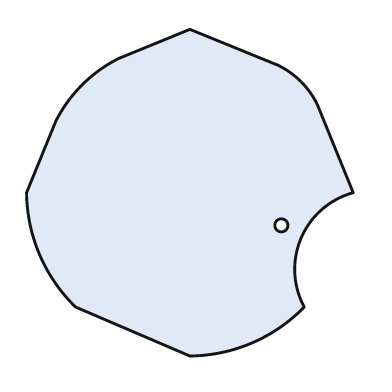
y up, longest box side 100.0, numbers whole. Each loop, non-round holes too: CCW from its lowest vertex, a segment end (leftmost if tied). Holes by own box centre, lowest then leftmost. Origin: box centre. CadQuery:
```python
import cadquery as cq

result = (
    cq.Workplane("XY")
    .moveTo(0.0, -50.0)
    .threePointArc((19.0, -46.0), (35.0, -35.0))
    .threePointArc((34.0, -14.0), (50.0, 0.0))
    .lineTo(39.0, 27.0)
    .threePointArc((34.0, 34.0), (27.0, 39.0))
    .lineTo(0.0, 50.0)
    .lineTo(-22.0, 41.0)
    .threePointArc((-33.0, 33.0), (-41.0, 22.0))
    .lineTo(-50.0, 0.0)
    .threePointArc((-46.0, -19.0), (-35.0, -35.0))
    .close()
    .moveTo(28.0, -10.0)
    .circle(2.0)
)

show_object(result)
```